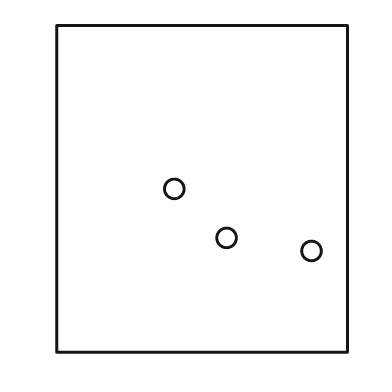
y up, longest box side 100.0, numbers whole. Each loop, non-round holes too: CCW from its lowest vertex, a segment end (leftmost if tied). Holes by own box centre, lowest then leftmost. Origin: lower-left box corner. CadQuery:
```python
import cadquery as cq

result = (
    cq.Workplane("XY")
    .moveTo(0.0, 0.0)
    .lineTo(89.0, 0.0)
    .lineTo(89.0, 100.0)
    .lineTo(0.0, 100.0)
    .close()
    .moveTo(78.0, 31.0)
    .circle(3.0)
    .moveTo(52.0, 35.0)
    .circle(3.0)
    .moveTo(36.0, 50.0)
    .circle(3.0)
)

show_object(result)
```